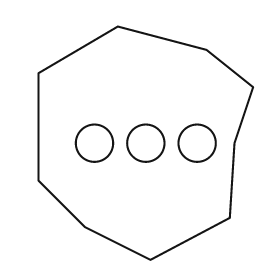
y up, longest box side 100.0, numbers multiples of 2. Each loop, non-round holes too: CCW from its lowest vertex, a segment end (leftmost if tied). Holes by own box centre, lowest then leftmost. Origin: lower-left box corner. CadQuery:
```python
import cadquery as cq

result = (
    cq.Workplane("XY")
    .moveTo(48.0, 0.0)
    .lineTo(82.0, 18.0)
    .lineTo(84.0, 50.0)
    .lineTo(92.0, 74.0)
    .lineTo(72.0, 90.0)
    .lineTo(34.0, 100.0)
    .lineTo(0.0, 80.0)
    .lineTo(0.0, 34.0)
    .lineTo(20.0, 14.0)
    .close()
    .moveTo(24.0, 50.0)
    .circle(8.0)
    .moveTo(46.0, 50.0)
    .circle(8.0)
    .moveTo(68.0, 50.0)
    .circle(8.0)
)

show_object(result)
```